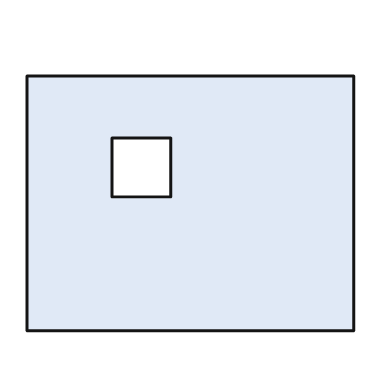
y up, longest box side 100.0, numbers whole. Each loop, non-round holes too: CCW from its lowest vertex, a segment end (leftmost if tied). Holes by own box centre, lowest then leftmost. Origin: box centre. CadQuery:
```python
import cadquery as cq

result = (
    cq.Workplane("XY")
    .moveTo(-50.0, -39.0)
    .lineTo(50.0, -39.0)
    .lineTo(50.0, 39.0)
    .lineTo(-50.0, 39.0)
    .close()
    .moveTo(-24.0, 2.0)
    .lineTo(-6.0, 2.0)
    .lineTo(-6.0, 20.0)
    .lineTo(-24.0, 20.0)
    .close()
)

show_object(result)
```